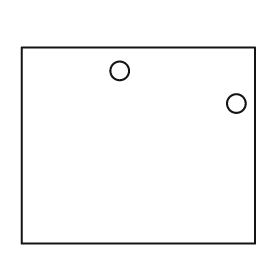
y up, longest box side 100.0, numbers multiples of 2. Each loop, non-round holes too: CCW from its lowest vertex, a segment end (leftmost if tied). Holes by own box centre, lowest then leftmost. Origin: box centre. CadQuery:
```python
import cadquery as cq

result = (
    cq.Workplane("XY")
    .moveTo(-50.0, -42.0)
    .lineTo(50.0, -42.0)
    .lineTo(50.0, 42.0)
    .lineTo(-50.0, 42.0)
    .close()
    .moveTo(42.0, 18.0)
    .circle(4.0)
    .moveTo(-8.0, 32.0)
    .circle(4.0)
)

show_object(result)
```